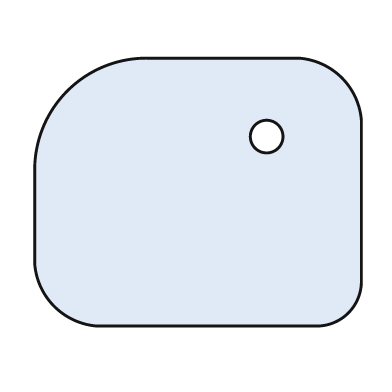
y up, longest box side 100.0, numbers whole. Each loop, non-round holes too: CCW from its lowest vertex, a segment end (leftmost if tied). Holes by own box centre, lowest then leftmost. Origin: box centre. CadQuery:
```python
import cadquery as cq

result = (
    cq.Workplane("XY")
    .moveTo(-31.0, -41.0)
    .lineTo(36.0, -41.0)
    .threePointArc((46.0, -37.0), (50.0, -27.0))
    .lineTo(50.0, 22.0)
    .threePointArc((44.0, 35.0), (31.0, 41.0))
    .lineTo(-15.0, 41.0)
    .threePointArc((-40.0, 31.0), (-50.0, 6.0))
    .lineTo(-50.0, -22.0)
    .threePointArc((-44.0, -35.0), (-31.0, -41.0))
    .close()
    .moveTo(21.0, 17.0)
    .circle(5.0)
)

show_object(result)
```